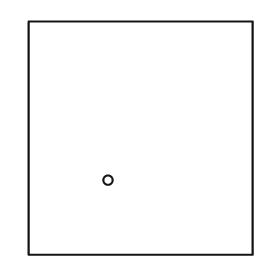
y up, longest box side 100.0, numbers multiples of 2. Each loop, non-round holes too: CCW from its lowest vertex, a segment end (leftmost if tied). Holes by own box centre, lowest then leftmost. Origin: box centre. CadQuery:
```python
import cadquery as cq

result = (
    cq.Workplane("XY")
    .moveTo(-48.0, -50.0)
    .lineTo(48.0, -50.0)
    .lineTo(48.0, 50.0)
    .lineTo(-48.0, 50.0)
    .close()
    .moveTo(-14.0, -18.0)
    .circle(2.0)
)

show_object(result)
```